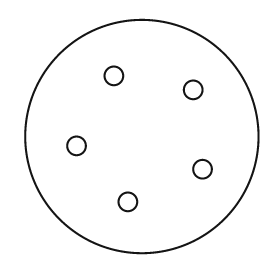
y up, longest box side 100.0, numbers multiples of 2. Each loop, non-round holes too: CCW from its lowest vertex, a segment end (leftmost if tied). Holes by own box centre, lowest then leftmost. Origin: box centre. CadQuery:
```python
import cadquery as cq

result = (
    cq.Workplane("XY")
    .moveTo(0.0, 0.0)
    .circle(50.0)
    .moveTo(-6.0, -28.0)
    .circle(4.0)
    .moveTo(26.0, -14.0)
    .circle(4.0)
    .moveTo(-28.0, -4.0)
    .circle(4.0)
    .moveTo(22.0, 20.0)
    .circle(4.0)
    .moveTo(-12.0, 26.0)
    .circle(4.0)
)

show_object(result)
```